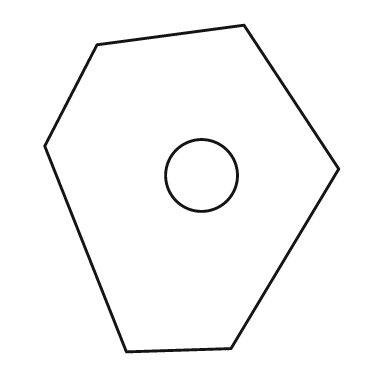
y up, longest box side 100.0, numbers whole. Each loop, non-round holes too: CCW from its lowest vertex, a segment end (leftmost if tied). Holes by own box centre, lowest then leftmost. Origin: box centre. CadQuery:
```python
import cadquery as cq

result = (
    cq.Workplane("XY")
    .moveTo(-20.0, -50.0)
    .lineTo(12.0, -49.0)
    .lineTo(45.0, 6.0)
    .lineTo(16.0, 50.0)
    .lineTo(-29.0, 44.0)
    .lineTo(-45.0, 13.0)
    .close()
    .moveTo(3.0, 4.0)
    .circle(11.0)
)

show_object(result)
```